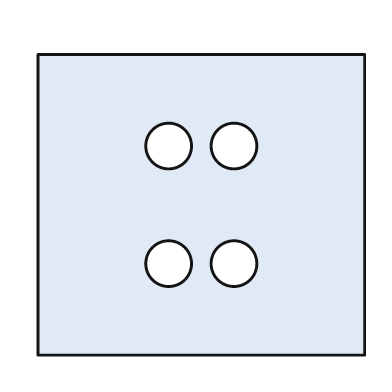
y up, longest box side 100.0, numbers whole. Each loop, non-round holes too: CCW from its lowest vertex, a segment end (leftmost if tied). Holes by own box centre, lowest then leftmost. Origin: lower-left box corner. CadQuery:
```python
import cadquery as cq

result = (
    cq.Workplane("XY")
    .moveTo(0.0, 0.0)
    .lineTo(100.0, 0.0)
    .lineTo(100.0, 92.0)
    .lineTo(0.0, 92.0)
    .close()
    .moveTo(40.0, 28.0)
    .circle(7.0)
    .moveTo(60.0, 28.0)
    .circle(7.0)
    .moveTo(40.0, 64.0)
    .circle(7.0)
    .moveTo(60.0, 64.0)
    .circle(7.0)
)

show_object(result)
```